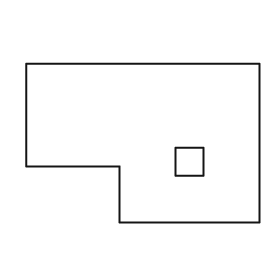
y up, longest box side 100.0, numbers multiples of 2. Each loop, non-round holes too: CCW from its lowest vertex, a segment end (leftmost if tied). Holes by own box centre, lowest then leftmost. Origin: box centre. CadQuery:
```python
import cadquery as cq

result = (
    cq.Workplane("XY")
    .moveTo(-10.0, -34.0)
    .lineTo(50.0, -34.0)
    .lineTo(50.0, 34.0)
    .lineTo(-50.0, 34.0)
    .lineTo(-50.0, -10.0)
    .lineTo(-10.0, -10.0)
    .close()
    .moveTo(14.0, -14.0)
    .lineTo(26.0, -14.0)
    .lineTo(26.0, -2.0)
    .lineTo(14.0, -2.0)
    .close()
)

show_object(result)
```